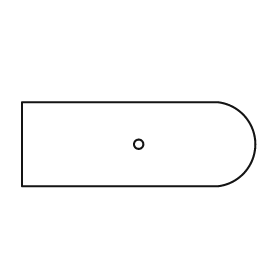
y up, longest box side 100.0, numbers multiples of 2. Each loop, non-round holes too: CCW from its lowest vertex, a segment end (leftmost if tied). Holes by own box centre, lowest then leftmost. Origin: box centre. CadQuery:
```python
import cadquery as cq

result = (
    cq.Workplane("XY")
    .moveTo(-50.0, -18.0)
    .lineTo(34.0, -18.0)
    .threePointArc((50.0, 0.0), (34.0, 18.0))
    .lineTo(-50.0, 18.0)
    .close()
    .moveTo(0.0, 0.0)
    .circle(2.0)
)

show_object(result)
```